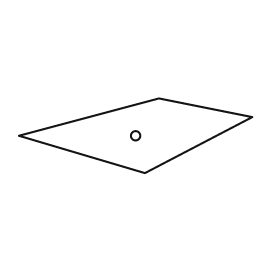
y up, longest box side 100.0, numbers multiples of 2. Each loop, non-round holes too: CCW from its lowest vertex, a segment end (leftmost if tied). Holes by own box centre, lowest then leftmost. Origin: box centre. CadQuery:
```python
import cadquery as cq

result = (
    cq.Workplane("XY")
    .moveTo(4.0, -16.0)
    .lineTo(50.0, 8.0)
    .lineTo(10.0, 16.0)
    .lineTo(-50.0, 0.0)
    .close()
    .moveTo(0.0, 0.0)
    .circle(2.0)
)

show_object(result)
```